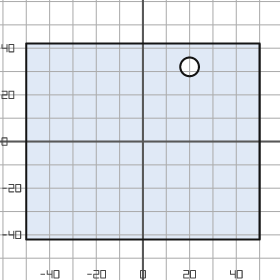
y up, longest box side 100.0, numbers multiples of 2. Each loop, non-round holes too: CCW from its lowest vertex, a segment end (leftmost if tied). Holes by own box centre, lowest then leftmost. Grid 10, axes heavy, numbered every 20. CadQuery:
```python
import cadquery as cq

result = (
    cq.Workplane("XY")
    .moveTo(-50.0, -42.0)
    .lineTo(50.0, -42.0)
    .lineTo(50.0, 42.0)
    .lineTo(-50.0, 42.0)
    .close()
    .moveTo(20.0, 32.0)
    .circle(4.0)
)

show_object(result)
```